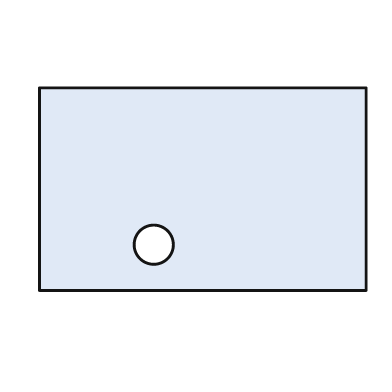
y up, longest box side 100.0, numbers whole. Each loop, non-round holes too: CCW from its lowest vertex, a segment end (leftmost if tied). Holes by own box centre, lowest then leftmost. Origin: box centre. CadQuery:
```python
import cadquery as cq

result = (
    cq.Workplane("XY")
    .moveTo(-50.0, -31.0)
    .lineTo(50.0, -31.0)
    .lineTo(50.0, 31.0)
    .lineTo(-50.0, 31.0)
    .close()
    .moveTo(-15.0, -17.0)
    .circle(6.0)
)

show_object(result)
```